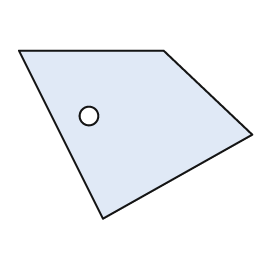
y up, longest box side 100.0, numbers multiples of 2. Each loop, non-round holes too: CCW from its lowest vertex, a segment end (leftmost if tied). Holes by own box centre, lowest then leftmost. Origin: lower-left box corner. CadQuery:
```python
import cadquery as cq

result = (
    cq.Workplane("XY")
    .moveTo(36.0, 0.0)
    .lineTo(100.0, 36.0)
    .lineTo(62.0, 72.0)
    .lineTo(0.0, 72.0)
    .close()
    .moveTo(30.0, 44.0)
    .circle(4.0)
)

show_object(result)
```